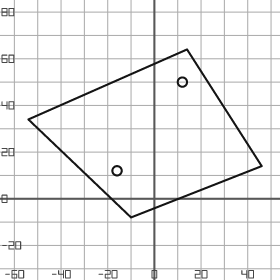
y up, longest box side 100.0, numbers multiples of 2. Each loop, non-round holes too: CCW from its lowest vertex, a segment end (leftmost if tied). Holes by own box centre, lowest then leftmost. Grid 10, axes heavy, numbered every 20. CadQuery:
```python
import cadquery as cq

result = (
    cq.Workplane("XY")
    .moveTo(-10.0, -8.0)
    .lineTo(46.0, 14.0)
    .lineTo(14.0, 64.0)
    .lineTo(-54.0, 34.0)
    .close()
    .moveTo(-16.0, 12.0)
    .circle(2.0)
    .moveTo(12.0, 50.0)
    .circle(2.0)
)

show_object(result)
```